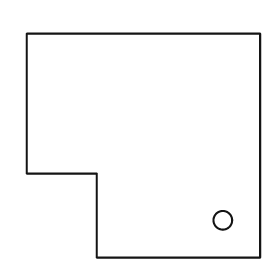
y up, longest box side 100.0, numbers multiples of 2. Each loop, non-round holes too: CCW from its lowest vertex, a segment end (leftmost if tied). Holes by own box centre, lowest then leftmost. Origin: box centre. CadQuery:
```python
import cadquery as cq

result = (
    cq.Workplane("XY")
    .moveTo(-20.0, -48.0)
    .lineTo(50.0, -48.0)
    .lineTo(50.0, 48.0)
    .lineTo(-50.0, 48.0)
    .lineTo(-50.0, -12.0)
    .lineTo(-20.0, -12.0)
    .close()
    .moveTo(34.0, -32.0)
    .circle(4.0)
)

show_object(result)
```